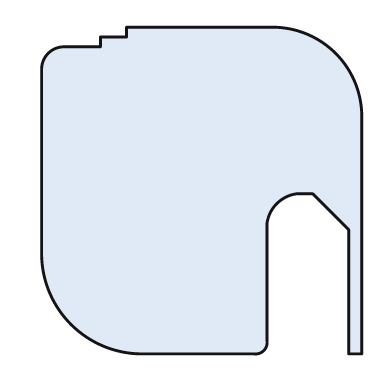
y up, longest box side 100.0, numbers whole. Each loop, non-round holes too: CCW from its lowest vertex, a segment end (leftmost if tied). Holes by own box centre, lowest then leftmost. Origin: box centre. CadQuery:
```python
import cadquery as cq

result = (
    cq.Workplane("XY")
    .moveTo(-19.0, -50.0)
    .lineTo(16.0, -50.0)
    .threePointArc((19.0, -49.0), (20.0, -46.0))
    .lineTo(20.0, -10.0)
    .threePointArc((23.0, -4.0), (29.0, -1.0))
    .lineTo(34.0, -1.0)
    .lineTo(45.0, -12.0)
    .lineTo(45.0, -50.0)
    .lineTo(49.0, -50.0)
    .lineTo(49.0, 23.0)
    .threePointArc((41.0, 42.0), (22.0, 50.0))
    .lineTo(-23.0, 50.0)
    .lineTo(-23.0, 47.0)
    .lineTo(-31.0, 47.0)
    .lineTo(-31.0, 44.0)
    .lineTo(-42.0, 44.0)
    .threePointArc((-47.0, 42.0), (-49.0, 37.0))
    .lineTo(-49.0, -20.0)
    .threePointArc((-40.0, -41.0), (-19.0, -50.0))
    .close()
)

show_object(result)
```